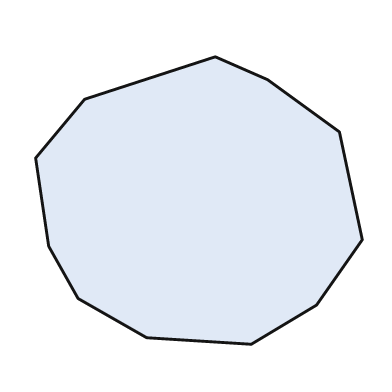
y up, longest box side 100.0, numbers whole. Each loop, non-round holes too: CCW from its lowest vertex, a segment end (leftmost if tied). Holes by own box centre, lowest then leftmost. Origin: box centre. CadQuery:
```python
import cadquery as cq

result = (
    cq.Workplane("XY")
    .moveTo(16.0, -44.0)
    .lineTo(36.0, -32.0)
    .lineTo(50.0, -12.0)
    .lineTo(43.0, 21.0)
    .lineTo(21.0, 37.0)
    .lineTo(5.0, 44.0)
    .lineTo(-35.0, 31.0)
    .lineTo(-50.0, 13.0)
    .lineTo(-46.0, -14.0)
    .lineTo(-37.0, -30.0)
    .lineTo(-16.0, -42.0)
    .close()
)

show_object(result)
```